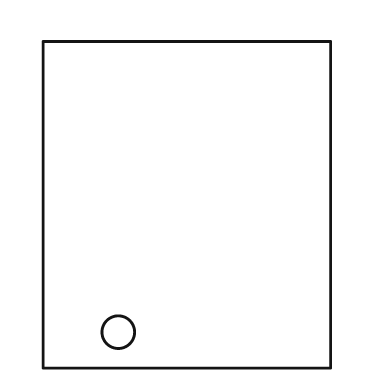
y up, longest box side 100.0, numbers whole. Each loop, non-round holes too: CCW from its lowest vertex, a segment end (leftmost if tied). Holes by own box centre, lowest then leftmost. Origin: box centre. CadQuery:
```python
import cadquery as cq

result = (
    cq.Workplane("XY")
    .moveTo(-44.0, -50.0)
    .lineTo(44.0, -50.0)
    .lineTo(44.0, 50.0)
    .lineTo(-44.0, 50.0)
    .close()
    .moveTo(-21.0, -39.0)
    .circle(5.0)
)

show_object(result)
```